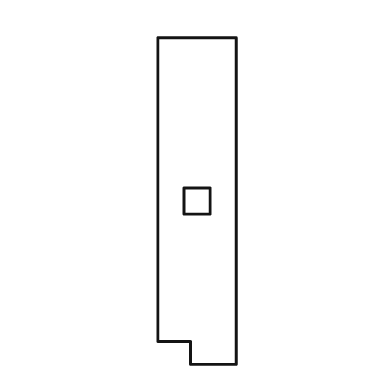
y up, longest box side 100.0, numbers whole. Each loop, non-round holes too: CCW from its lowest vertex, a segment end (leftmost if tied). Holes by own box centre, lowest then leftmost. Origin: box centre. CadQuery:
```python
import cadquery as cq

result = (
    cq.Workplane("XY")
    .moveTo(-2.0, -50.0)
    .lineTo(12.0, -50.0)
    .lineTo(12.0, 50.0)
    .lineTo(-12.0, 50.0)
    .lineTo(-12.0, -43.0)
    .lineTo(-2.0, -43.0)
    .close()
    .moveTo(-4.0, -4.0)
    .lineTo(4.0, -4.0)
    .lineTo(4.0, 4.0)
    .lineTo(-4.0, 4.0)
    .close()
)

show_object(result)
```